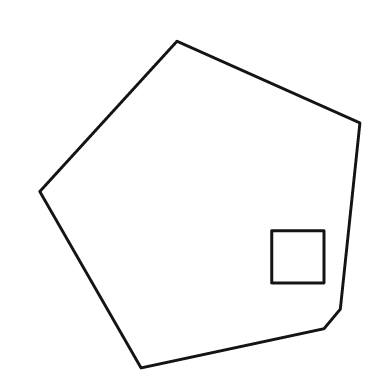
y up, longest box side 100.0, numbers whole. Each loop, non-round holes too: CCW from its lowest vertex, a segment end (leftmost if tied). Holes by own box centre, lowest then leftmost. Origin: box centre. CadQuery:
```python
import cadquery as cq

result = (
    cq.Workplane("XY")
    .moveTo(-18.0, -50.0)
    .lineTo(38.0, -38.0)
    .lineTo(43.0, -32.0)
    .lineTo(49.0, 25.0)
    .lineTo(-7.0, 50.0)
    .lineTo(-49.0, 4.0)
    .close()
    .moveTo(22.0, -24.0)
    .lineTo(38.0, -24.0)
    .lineTo(38.0, -8.0)
    .lineTo(22.0, -8.0)
    .close()
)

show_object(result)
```